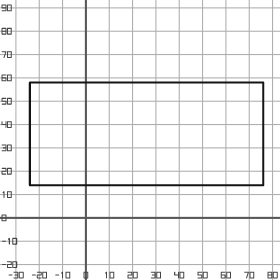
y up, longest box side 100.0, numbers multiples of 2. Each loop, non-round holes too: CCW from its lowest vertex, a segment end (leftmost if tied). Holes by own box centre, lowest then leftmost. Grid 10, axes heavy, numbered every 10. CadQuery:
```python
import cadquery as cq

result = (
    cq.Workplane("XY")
    .moveTo(-24.0, 14.0)
    .lineTo(76.0, 14.0)
    .lineTo(76.0, 58.0)
    .lineTo(-24.0, 58.0)
    .close()
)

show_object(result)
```